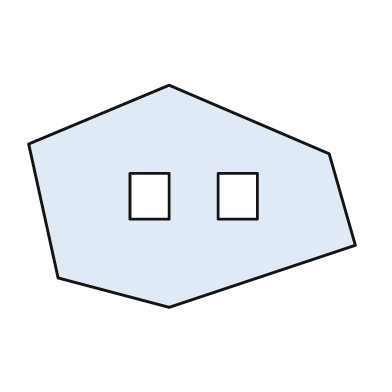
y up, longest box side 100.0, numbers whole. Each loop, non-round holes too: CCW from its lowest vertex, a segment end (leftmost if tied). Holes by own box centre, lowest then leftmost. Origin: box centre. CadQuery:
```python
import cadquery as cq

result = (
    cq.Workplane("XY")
    .moveTo(-7.0, -34.0)
    .lineTo(50.0, -15.0)
    .lineTo(42.0, 13.0)
    .lineTo(-7.0, 34.0)
    .lineTo(-50.0, 16.0)
    .lineTo(-41.0, -25.0)
    .close()
    .moveTo(-19.0, -7.0)
    .lineTo(-7.0, -7.0)
    .lineTo(-7.0, 7.0)
    .lineTo(-19.0, 7.0)
    .close()
    .moveTo(8.0, -7.0)
    .lineTo(20.0, -7.0)
    .lineTo(20.0, 7.0)
    .lineTo(8.0, 7.0)
    .close()
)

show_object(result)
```